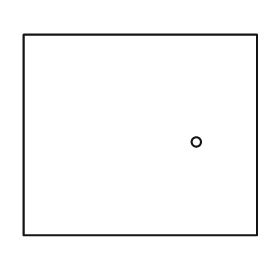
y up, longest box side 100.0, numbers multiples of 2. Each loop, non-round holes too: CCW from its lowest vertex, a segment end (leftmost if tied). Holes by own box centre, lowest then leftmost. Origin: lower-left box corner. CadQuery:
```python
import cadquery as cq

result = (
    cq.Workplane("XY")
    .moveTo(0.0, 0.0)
    .lineTo(100.0, 0.0)
    .lineTo(100.0, 86.0)
    .lineTo(0.0, 86.0)
    .close()
    .moveTo(74.0, 40.0)
    .circle(2.0)
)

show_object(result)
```